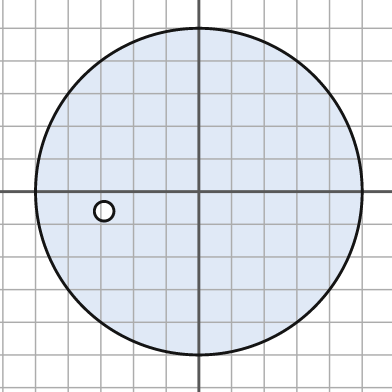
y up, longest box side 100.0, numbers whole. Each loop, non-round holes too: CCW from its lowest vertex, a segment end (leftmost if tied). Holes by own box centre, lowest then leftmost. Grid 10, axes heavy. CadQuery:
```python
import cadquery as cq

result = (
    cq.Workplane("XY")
    .moveTo(0.0, 0.0)
    .circle(50.0)
    .moveTo(-29.0, -6.0)
    .circle(3.0)
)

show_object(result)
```